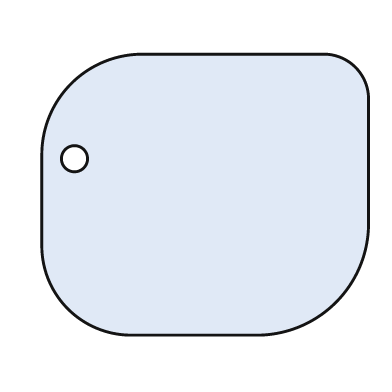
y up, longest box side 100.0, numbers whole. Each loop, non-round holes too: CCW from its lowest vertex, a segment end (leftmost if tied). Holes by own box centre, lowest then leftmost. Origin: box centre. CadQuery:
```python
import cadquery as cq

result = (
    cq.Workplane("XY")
    .moveTo(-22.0, -43.0)
    .lineTo(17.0, -43.0)
    .threePointArc((40.0, -33.0), (50.0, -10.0))
    .lineTo(50.0, 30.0)
    .threePointArc((46.0, 39.0), (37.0, 43.0))
    .lineTo(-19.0, 43.0)
    .threePointArc((-41.0, 34.0), (-50.0, 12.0))
    .lineTo(-50.0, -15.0)
    .threePointArc((-42.0, -35.0), (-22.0, -43.0))
    .close()
    .moveTo(-40.0, 11.0)
    .circle(4.0)
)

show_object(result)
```